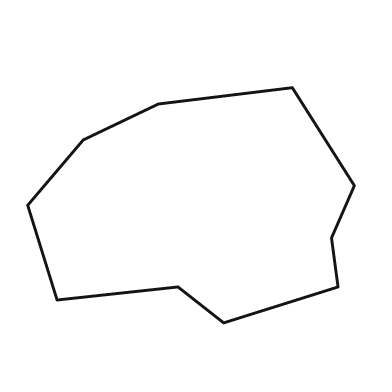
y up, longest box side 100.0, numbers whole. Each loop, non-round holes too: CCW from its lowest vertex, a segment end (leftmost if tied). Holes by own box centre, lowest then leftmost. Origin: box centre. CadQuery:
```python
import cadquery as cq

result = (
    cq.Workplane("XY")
    .moveTo(10.0, -36.0)
    .lineTo(45.0, -25.0)
    .lineTo(43.0, -10.0)
    .lineTo(50.0, 6.0)
    .lineTo(31.0, 36.0)
    .lineTo(-10.0, 31.0)
    .lineTo(-33.0, 20.0)
    .lineTo(-50.0, 0.0)
    .lineTo(-41.0, -29.0)
    .lineTo(-4.0, -25.0)
    .close()
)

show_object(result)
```